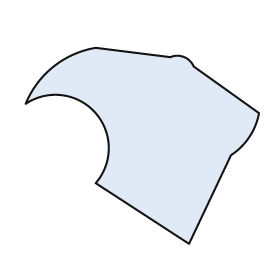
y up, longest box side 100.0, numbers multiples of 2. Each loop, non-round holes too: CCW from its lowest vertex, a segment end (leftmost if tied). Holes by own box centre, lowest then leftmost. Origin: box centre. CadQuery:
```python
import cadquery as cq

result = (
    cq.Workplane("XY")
    .moveTo(20.0, -42.0)
    .lineTo(38.0, -4.0)
    .threePointArc((46.0, 4.0), (50.0, 14.0))
    .lineTo(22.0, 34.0)
    .threePointArc((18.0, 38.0), (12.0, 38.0))
    .lineTo(-20.0, 42.0)
    .threePointArc((-38.0, 34.0), (-50.0, 18.0))
    .threePointArc((-20.0, 14.0), (-20.0, -16.0))
    .close()
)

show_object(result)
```